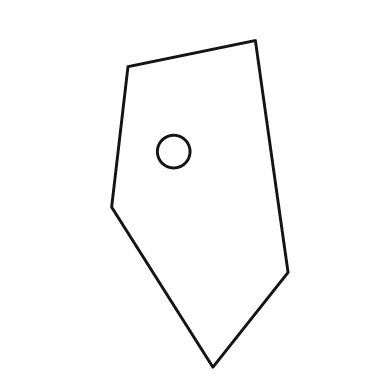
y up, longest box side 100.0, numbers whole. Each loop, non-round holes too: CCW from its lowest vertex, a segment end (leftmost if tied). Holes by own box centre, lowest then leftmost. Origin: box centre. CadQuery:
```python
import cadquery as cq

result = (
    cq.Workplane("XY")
    .moveTo(4.0, -50.0)
    .lineTo(27.0, -21.0)
    .lineTo(17.0, 50.0)
    .lineTo(-22.0, 42.0)
    .lineTo(-27.0, -1.0)
    .close()
    .moveTo(-8.0, 16.0)
    .circle(5.0)
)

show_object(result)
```